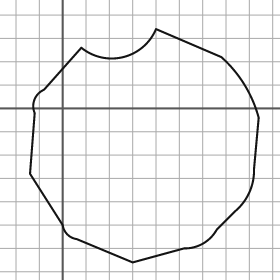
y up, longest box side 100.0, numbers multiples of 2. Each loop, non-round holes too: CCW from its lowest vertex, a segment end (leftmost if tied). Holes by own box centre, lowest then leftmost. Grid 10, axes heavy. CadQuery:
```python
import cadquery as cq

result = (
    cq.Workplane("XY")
    .moveTo(30.0, -66.0)
    .lineTo(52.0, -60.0)
    .threePointArc((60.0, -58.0), (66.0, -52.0))
    .lineTo(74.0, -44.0)
    .threePointArc((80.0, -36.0), (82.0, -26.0))
    .lineTo(84.0, -4.0)
    .threePointArc((78.0, 10.0), (68.0, 22.0))
    .lineTo(40.0, 34.0)
    .threePointArc((26.0, 22.0), (8.0, 26.0))
    .lineTo(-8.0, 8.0)
    .threePointArc((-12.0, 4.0), (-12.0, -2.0))
    .lineTo(-14.0, -28.0)
    .lineTo(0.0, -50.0)
    .threePointArc((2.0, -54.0), (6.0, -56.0))
    .close()
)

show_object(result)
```